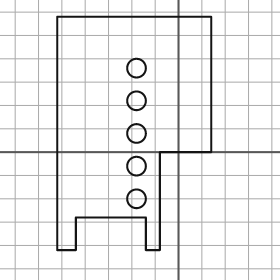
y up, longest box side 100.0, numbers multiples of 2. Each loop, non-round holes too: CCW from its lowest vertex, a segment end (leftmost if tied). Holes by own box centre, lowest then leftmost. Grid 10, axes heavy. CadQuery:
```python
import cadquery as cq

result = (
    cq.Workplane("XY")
    .moveTo(-52.0, -42.0)
    .lineTo(-44.0, -42.0)
    .lineTo(-44.0, -28.0)
    .lineTo(-14.0, -28.0)
    .lineTo(-14.0, -42.0)
    .lineTo(-8.0, -42.0)
    .lineTo(-8.0, 0.0)
    .lineTo(14.0, 0.0)
    .lineTo(14.0, 58.0)
    .lineTo(-52.0, 58.0)
    .close()
    .moveTo(-18.0, -20.0)
    .circle(4.0)
    .moveTo(-18.0, -6.0)
    .circle(4.0)
    .moveTo(-18.0, 8.0)
    .circle(4.0)
    .moveTo(-18.0, 22.0)
    .circle(4.0)
    .moveTo(-18.0, 36.0)
    .circle(4.0)
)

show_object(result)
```